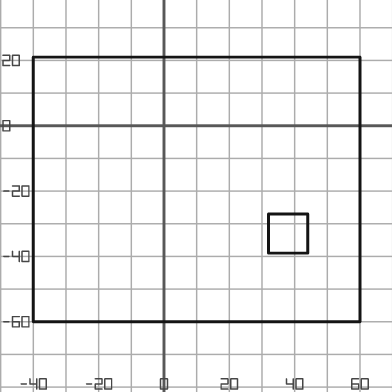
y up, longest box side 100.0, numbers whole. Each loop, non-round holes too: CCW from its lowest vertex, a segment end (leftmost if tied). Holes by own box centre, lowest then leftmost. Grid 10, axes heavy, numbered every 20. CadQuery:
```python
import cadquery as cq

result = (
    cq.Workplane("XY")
    .moveTo(-40.0, -60.0)
    .lineTo(60.0, -60.0)
    .lineTo(60.0, 21.0)
    .lineTo(-40.0, 21.0)
    .close()
    .moveTo(32.0, -39.0)
    .lineTo(44.0, -39.0)
    .lineTo(44.0, -27.0)
    .lineTo(32.0, -27.0)
    .close()
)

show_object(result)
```